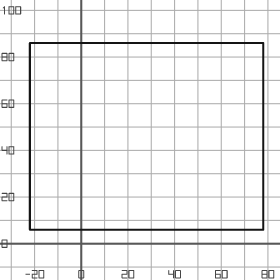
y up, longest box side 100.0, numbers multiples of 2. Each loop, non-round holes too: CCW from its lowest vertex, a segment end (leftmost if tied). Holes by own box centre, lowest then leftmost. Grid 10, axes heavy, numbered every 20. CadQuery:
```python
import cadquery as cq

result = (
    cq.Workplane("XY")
    .moveTo(-22.0, 6.0)
    .lineTo(78.0, 6.0)
    .lineTo(78.0, 86.0)
    .lineTo(-22.0, 86.0)
    .close()
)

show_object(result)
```